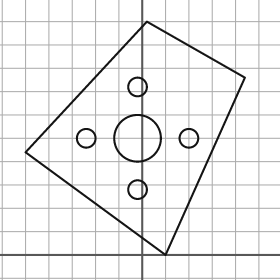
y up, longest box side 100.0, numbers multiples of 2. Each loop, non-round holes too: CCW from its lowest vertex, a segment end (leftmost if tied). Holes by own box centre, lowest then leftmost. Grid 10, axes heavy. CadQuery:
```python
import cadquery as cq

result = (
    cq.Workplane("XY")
    .moveTo(10.0, 0.0)
    .lineTo(44.0, 76.0)
    .lineTo(2.0, 100.0)
    .lineTo(-50.0, 44.0)
    .close()
    .moveTo(-2.0, 28.0)
    .circle(4.0)
    .moveTo(-24.0, 50.0)
    .circle(4.0)
    .moveTo(-2.0, 50.0)
    .circle(10.0)
    .moveTo(20.0, 50.0)
    .circle(4.0)
    .moveTo(-2.0, 72.0)
    .circle(4.0)
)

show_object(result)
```